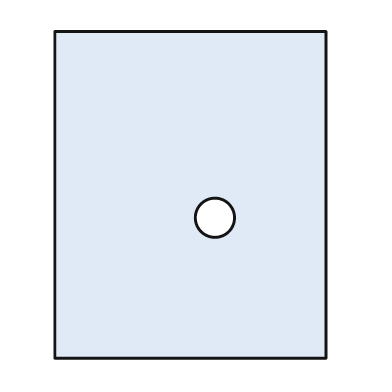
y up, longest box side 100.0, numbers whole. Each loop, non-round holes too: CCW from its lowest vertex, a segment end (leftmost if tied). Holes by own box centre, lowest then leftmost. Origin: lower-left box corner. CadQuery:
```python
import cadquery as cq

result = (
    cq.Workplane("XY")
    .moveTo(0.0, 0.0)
    .lineTo(83.0, 0.0)
    .lineTo(83.0, 100.0)
    .lineTo(0.0, 100.0)
    .close()
    .moveTo(49.0, 43.0)
    .circle(6.0)
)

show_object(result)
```